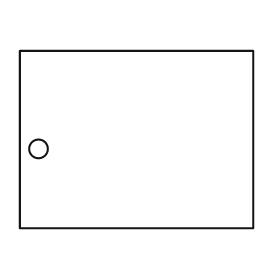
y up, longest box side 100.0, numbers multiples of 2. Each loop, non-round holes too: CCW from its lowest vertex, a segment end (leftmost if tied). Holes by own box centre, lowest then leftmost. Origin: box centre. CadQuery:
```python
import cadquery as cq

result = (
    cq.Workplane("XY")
    .moveTo(-50.0, -38.0)
    .lineTo(50.0, -38.0)
    .lineTo(50.0, 38.0)
    .lineTo(-50.0, 38.0)
    .close()
    .moveTo(-42.0, -4.0)
    .circle(4.0)
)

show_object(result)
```